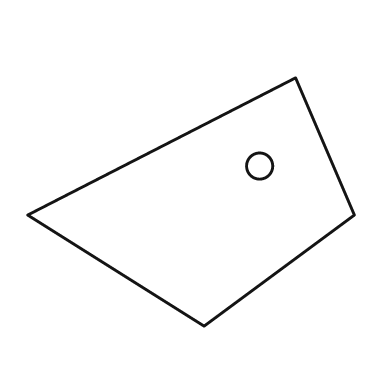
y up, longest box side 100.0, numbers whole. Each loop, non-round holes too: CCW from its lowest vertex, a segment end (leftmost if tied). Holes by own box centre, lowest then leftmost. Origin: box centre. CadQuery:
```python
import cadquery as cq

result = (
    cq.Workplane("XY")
    .moveTo(4.0, -38.0)
    .lineTo(50.0, -4.0)
    .lineTo(32.0, 38.0)
    .lineTo(-50.0, -4.0)
    .close()
    .moveTo(21.0, 11.0)
    .circle(4.0)
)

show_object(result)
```